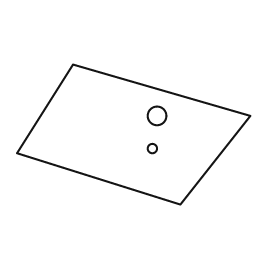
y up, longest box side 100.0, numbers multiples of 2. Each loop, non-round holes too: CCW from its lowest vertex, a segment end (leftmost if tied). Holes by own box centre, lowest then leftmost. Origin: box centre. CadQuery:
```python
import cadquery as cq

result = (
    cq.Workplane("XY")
    .moveTo(20.0, -30.0)
    .lineTo(50.0, 8.0)
    .lineTo(-26.0, 30.0)
    .lineTo(-50.0, -8.0)
    .close()
    .moveTo(8.0, -6.0)
    .circle(2.0)
    .moveTo(10.0, 8.0)
    .circle(4.0)
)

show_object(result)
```